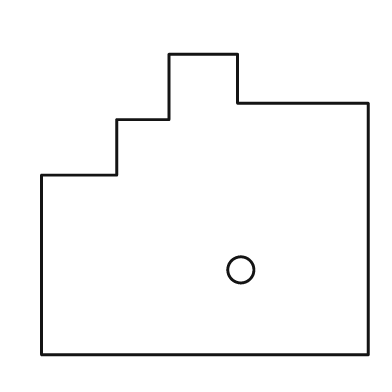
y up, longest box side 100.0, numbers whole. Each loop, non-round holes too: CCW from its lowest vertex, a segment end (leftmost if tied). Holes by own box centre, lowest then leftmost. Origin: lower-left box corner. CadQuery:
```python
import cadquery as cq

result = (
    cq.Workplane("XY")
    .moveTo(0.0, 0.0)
    .lineTo(100.0, 0.0)
    .lineTo(100.0, 77.0)
    .lineTo(60.0, 77.0)
    .lineTo(60.0, 92.0)
    .lineTo(39.0, 92.0)
    .lineTo(39.0, 72.0)
    .lineTo(23.0, 72.0)
    .lineTo(23.0, 55.0)
    .lineTo(0.0, 55.0)
    .close()
    .moveTo(61.0, 26.0)
    .circle(4.0)
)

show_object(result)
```